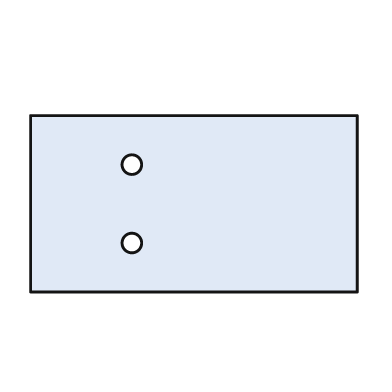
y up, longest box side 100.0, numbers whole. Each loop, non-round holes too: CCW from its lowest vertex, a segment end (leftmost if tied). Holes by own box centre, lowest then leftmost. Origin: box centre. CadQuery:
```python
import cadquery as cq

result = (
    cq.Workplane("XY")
    .moveTo(-50.0, -27.0)
    .lineTo(50.0, -27.0)
    .lineTo(50.0, 27.0)
    .lineTo(-50.0, 27.0)
    .close()
    .moveTo(-19.0, -12.0)
    .circle(3.0)
    .moveTo(-19.0, 12.0)
    .circle(3.0)
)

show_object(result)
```